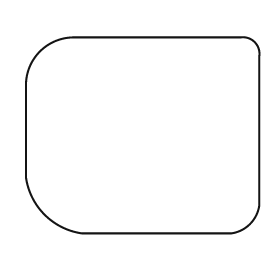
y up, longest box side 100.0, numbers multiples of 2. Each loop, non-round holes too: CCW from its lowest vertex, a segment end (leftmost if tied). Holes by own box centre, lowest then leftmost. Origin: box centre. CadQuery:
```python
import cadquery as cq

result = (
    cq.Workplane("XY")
    .moveTo(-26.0, -42.0)
    .lineTo(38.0, -42.0)
    .threePointArc((46.0, -38.0), (50.0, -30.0))
    .lineTo(50.0, 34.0)
    .threePointArc((48.0, 40.0), (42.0, 42.0))
    .lineTo(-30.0, 42.0)
    .threePointArc((-44.0, 36.0), (-50.0, 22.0))
    .lineTo(-50.0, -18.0)
    .threePointArc((-42.0, -34.0), (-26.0, -42.0))
    .close()
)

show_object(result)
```